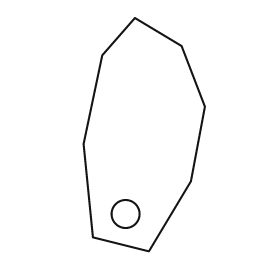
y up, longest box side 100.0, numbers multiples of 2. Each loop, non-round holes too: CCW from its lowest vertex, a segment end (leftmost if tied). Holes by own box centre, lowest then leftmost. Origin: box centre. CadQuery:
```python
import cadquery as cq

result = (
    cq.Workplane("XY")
    .moveTo(2.0, -50.0)
    .lineTo(20.0, -20.0)
    .lineTo(26.0, 12.0)
    .lineTo(16.0, 38.0)
    .lineTo(-4.0, 50.0)
    .lineTo(-18.0, 34.0)
    .lineTo(-26.0, -4.0)
    .lineTo(-22.0, -44.0)
    .close()
    .moveTo(-8.0, -34.0)
    .circle(6.0)
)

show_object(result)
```